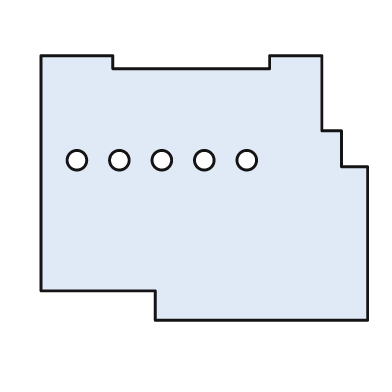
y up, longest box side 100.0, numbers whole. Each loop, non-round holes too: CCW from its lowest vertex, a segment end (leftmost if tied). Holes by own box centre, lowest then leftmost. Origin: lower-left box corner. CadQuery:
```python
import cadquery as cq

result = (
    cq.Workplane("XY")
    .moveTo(35.0, 0.0)
    .lineTo(100.0, 0.0)
    .lineTo(100.0, 47.0)
    .lineTo(92.0, 47.0)
    .lineTo(92.0, 58.0)
    .lineTo(86.0, 58.0)
    .lineTo(86.0, 81.0)
    .lineTo(70.0, 81.0)
    .lineTo(70.0, 77.0)
    .lineTo(22.0, 77.0)
    .lineTo(22.0, 81.0)
    .lineTo(0.0, 81.0)
    .lineTo(0.0, 9.0)
    .lineTo(35.0, 9.0)
    .close()
    .moveTo(11.0, 49.0)
    .circle(3.0)
    .moveTo(24.0, 49.0)
    .circle(3.0)
    .moveTo(37.0, 49.0)
    .circle(3.0)
    .moveTo(50.0, 49.0)
    .circle(3.0)
    .moveTo(63.0, 49.0)
    .circle(3.0)
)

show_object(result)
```